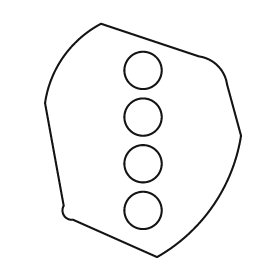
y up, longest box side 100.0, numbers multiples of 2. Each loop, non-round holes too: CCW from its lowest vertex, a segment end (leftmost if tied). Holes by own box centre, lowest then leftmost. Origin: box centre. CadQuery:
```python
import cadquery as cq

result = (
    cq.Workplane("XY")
    .moveTo(6.0, -50.0)
    .threePointArc((30.0, -28.0), (42.0, 2.0))
    .lineTo(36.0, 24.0)
    .threePointArc((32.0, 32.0), (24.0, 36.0))
    .lineTo(-18.0, 50.0)
    .threePointArc((-34.0, 36.0), (-42.0, 16.0))
    .lineTo(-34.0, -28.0)
    .threePointArc((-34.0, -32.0), (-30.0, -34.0))
    .close()
    .moveTo(0.0, -30.0)
    .circle(8.0)
    .moveTo(0.0, -10.0)
    .circle(8.0)
    .moveTo(0.0, 10.0)
    .circle(8.0)
    .moveTo(0.0, 30.0)
    .circle(8.0)
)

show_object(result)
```